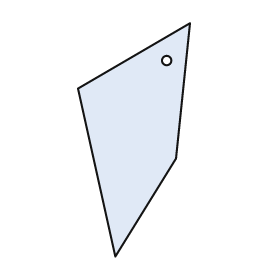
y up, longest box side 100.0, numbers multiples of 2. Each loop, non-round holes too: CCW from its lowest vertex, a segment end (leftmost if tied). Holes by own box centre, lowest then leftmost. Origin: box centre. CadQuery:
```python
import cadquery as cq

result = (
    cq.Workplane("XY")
    .moveTo(-8.0, -50.0)
    .lineTo(18.0, -8.0)
    .lineTo(24.0, 50.0)
    .lineTo(-24.0, 22.0)
    .close()
    .moveTo(14.0, 34.0)
    .circle(2.0)
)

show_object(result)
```